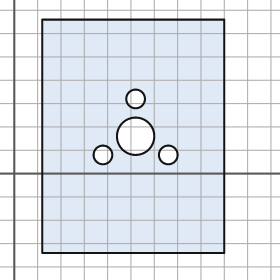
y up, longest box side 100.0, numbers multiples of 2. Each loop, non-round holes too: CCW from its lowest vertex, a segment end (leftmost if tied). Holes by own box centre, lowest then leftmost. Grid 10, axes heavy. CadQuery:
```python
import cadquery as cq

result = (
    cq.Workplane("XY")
    .moveTo(12.0, -34.0)
    .lineTo(90.0, -34.0)
    .lineTo(90.0, 66.0)
    .lineTo(12.0, 66.0)
    .close()
    .moveTo(38.0, 8.0)
    .circle(4.0)
    .moveTo(66.0, 8.0)
    .circle(4.0)
    .moveTo(52.0, 16.0)
    .circle(8.0)
    .moveTo(52.0, 32.0)
    .circle(4.0)
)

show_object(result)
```